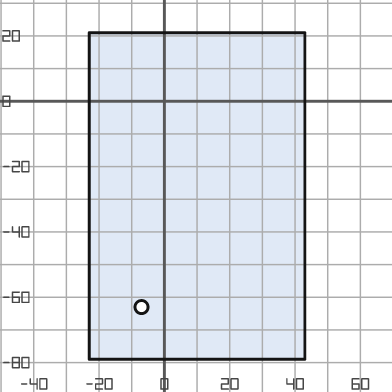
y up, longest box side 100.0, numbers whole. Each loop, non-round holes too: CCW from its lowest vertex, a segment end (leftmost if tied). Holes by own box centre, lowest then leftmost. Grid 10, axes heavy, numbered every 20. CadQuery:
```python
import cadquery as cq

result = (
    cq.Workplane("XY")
    .moveTo(-23.0, -79.0)
    .lineTo(43.0, -79.0)
    .lineTo(43.0, 21.0)
    .lineTo(-23.0, 21.0)
    .close()
    .moveTo(-7.0, -63.0)
    .circle(2.0)
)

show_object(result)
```